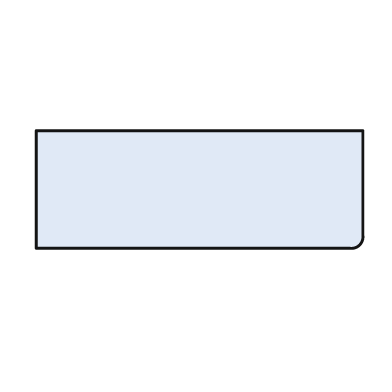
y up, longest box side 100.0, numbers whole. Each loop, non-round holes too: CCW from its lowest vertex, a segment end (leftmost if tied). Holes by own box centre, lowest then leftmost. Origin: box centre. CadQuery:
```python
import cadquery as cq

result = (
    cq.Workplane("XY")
    .moveTo(-50.0, -18.0)
    .lineTo(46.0, -18.0)
    .threePointArc((49.0, -17.0), (50.0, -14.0))
    .lineTo(50.0, 18.0)
    .lineTo(-50.0, 18.0)
    .close()
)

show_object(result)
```